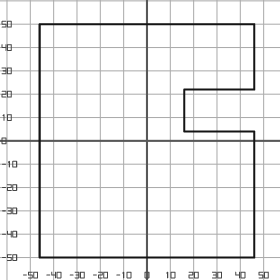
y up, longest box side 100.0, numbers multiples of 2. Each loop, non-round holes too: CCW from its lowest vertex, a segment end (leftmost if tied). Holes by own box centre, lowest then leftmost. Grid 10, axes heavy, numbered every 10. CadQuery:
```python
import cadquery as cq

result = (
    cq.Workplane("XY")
    .moveTo(-46.0, -50.0)
    .lineTo(46.0, -50.0)
    .lineTo(46.0, 4.0)
    .lineTo(16.0, 4.0)
    .lineTo(16.0, 22.0)
    .lineTo(46.0, 22.0)
    .lineTo(46.0, 50.0)
    .lineTo(-46.0, 50.0)
    .close()
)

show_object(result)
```